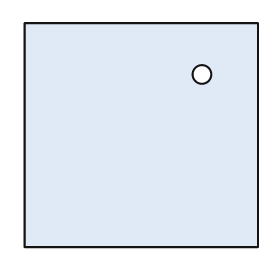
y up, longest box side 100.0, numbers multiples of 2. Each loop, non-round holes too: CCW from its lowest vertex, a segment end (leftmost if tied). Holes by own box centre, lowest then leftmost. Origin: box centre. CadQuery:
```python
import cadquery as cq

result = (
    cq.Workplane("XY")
    .moveTo(-50.0, -48.0)
    .lineTo(50.0, -48.0)
    .lineTo(50.0, 48.0)
    .lineTo(-50.0, 48.0)
    .close()
    .moveTo(26.0, 26.0)
    .circle(4.0)
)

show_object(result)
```